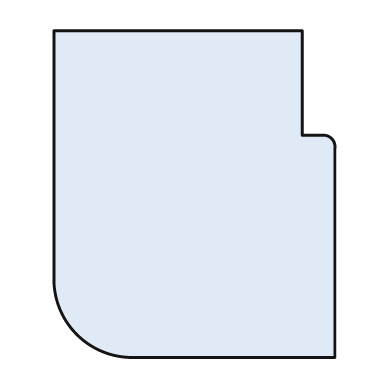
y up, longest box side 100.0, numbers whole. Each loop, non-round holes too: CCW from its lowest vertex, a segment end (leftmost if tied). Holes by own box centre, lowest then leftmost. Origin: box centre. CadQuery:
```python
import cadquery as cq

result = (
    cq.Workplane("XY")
    .moveTo(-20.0, -50.0)
    .lineTo(43.0, -50.0)
    .lineTo(43.0, 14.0)
    .threePointArc((42.0, 17.0), (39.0, 18.0))
    .lineTo(33.0, 18.0)
    .lineTo(33.0, 50.0)
    .lineTo(-43.0, 50.0)
    .lineTo(-43.0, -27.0)
    .threePointArc((-36.0, -43.0), (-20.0, -50.0))
    .close()
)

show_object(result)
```